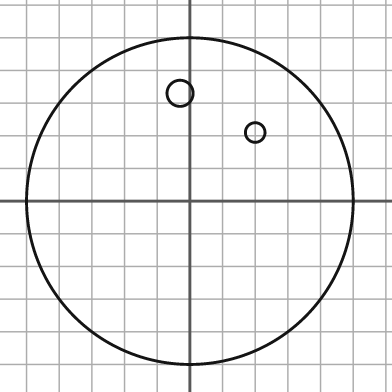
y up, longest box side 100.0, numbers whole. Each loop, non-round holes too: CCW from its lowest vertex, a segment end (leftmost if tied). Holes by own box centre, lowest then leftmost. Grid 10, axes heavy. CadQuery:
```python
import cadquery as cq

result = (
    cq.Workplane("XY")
    .moveTo(0.0, 0.0)
    .circle(50.0)
    .moveTo(20.0, 21.0)
    .circle(3.0)
    .moveTo(-3.0, 33.0)
    .circle(4.0)
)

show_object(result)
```